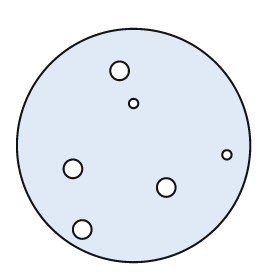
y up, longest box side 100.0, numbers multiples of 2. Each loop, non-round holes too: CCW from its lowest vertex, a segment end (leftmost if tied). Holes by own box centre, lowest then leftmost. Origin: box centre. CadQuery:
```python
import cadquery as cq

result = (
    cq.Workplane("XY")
    .moveTo(0.0, 0.0)
    .circle(50.0)
    .moveTo(-22.0, -36.0)
    .circle(4.0)
    .moveTo(14.0, -18.0)
    .circle(4.0)
    .moveTo(-26.0, -10.0)
    .circle(4.0)
    .moveTo(40.0, -4.0)
    .circle(2.0)
    .moveTo(0.0, 18.0)
    .circle(2.0)
    .moveTo(-6.0, 32.0)
    .circle(4.0)
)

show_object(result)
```